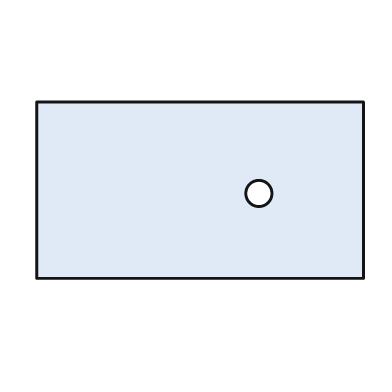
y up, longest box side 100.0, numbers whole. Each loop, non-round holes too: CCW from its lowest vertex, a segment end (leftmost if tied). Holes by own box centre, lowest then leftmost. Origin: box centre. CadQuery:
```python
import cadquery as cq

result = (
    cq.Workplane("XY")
    .moveTo(-50.0, -27.0)
    .lineTo(50.0, -27.0)
    .lineTo(50.0, 27.0)
    .lineTo(-50.0, 27.0)
    .close()
    .moveTo(18.0, -1.0)
    .circle(4.0)
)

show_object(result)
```